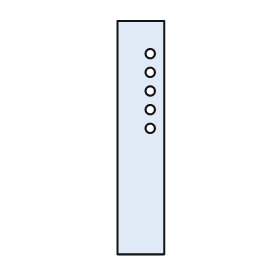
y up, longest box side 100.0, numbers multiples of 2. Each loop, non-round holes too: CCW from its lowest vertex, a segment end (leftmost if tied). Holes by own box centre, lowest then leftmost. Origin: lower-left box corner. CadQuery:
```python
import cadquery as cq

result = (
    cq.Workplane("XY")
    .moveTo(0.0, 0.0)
    .lineTo(20.0, 0.0)
    .lineTo(20.0, 100.0)
    .lineTo(0.0, 100.0)
    .close()
    .moveTo(14.0, 54.0)
    .circle(2.0)
    .moveTo(14.0, 62.0)
    .circle(2.0)
    .moveTo(14.0, 70.0)
    .circle(2.0)
    .moveTo(14.0, 78.0)
    .circle(2.0)
    .moveTo(14.0, 86.0)
    .circle(2.0)
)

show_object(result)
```